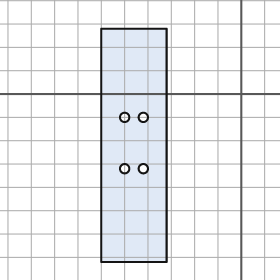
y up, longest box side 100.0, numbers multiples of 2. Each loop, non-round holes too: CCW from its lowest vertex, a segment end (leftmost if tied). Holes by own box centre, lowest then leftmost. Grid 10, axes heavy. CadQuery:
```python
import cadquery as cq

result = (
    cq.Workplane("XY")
    .moveTo(-60.0, -72.0)
    .lineTo(-32.0, -72.0)
    .lineTo(-32.0, 28.0)
    .lineTo(-60.0, 28.0)
    .close()
    .moveTo(-50.0, -32.0)
    .circle(2.0)
    .moveTo(-42.0, -32.0)
    .circle(2.0)
    .moveTo(-50.0, -10.0)
    .circle(2.0)
    .moveTo(-42.0, -10.0)
    .circle(2.0)
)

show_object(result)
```